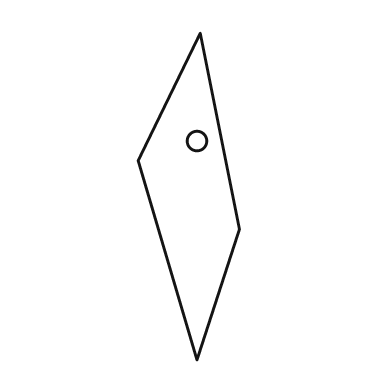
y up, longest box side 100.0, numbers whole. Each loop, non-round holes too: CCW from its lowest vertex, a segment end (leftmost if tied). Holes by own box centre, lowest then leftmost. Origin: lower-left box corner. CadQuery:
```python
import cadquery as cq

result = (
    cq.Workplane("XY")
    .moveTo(18.0, 0.0)
    .lineTo(31.0, 40.0)
    .lineTo(19.0, 100.0)
    .lineTo(0.0, 61.0)
    .close()
    .moveTo(18.0, 67.0)
    .circle(3.0)
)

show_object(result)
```